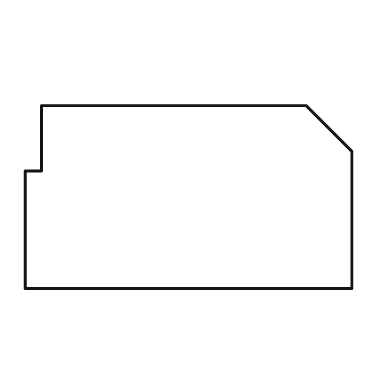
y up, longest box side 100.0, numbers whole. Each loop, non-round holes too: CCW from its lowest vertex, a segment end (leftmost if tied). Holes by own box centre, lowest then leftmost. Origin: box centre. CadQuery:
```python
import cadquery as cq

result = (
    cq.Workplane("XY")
    .moveTo(-50.0, -28.0)
    .lineTo(50.0, -28.0)
    .lineTo(50.0, 14.0)
    .lineTo(36.0, 28.0)
    .lineTo(-45.0, 28.0)
    .lineTo(-45.0, 8.0)
    .lineTo(-50.0, 8.0)
    .close()
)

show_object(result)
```